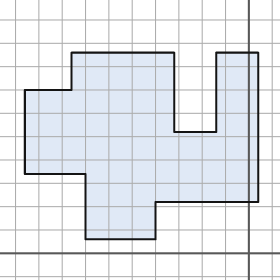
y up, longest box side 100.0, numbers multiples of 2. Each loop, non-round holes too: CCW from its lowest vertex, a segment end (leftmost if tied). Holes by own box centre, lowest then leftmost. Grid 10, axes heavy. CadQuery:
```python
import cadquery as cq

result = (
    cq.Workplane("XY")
    .moveTo(-70.0, 6.0)
    .lineTo(-40.0, 6.0)
    .lineTo(-40.0, 22.0)
    .lineTo(4.0, 22.0)
    .lineTo(4.0, 86.0)
    .lineTo(-14.0, 86.0)
    .lineTo(-14.0, 52.0)
    .lineTo(-32.0, 52.0)
    .lineTo(-32.0, 86.0)
    .lineTo(-76.0, 86.0)
    .lineTo(-76.0, 70.0)
    .lineTo(-96.0, 70.0)
    .lineTo(-96.0, 34.0)
    .lineTo(-70.0, 34.0)
    .close()
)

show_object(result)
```